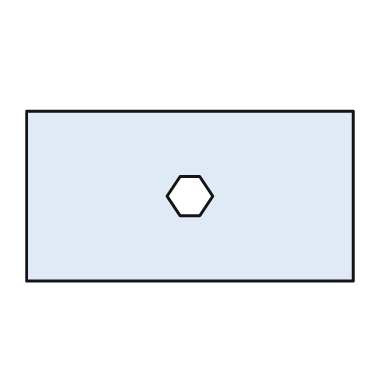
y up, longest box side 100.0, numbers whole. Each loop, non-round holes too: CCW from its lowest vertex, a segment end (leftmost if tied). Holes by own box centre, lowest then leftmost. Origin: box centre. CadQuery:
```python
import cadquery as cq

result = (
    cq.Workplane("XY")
    .moveTo(-50.0, -26.0)
    .lineTo(50.0, -26.0)
    .lineTo(50.0, 26.0)
    .lineTo(-50.0, 26.0)
    .close()
    .moveTo(-3.0, -6.0)
    .lineTo(3.0, -6.0)
    .lineTo(7.0, 0.0)
    .lineTo(3.0, 6.0)
    .lineTo(-3.0, 6.0)
    .lineTo(-7.0, 0.0)
    .close()
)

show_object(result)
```